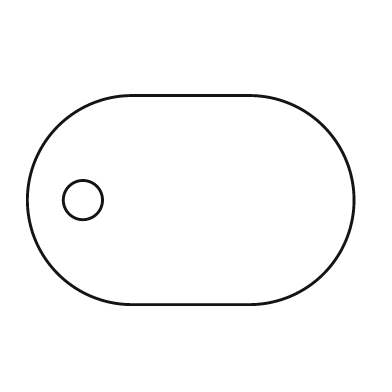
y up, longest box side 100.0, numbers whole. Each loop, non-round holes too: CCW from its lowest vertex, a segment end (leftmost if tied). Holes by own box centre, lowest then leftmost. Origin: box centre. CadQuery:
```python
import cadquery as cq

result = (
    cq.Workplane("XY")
    .moveTo(-18.0, -32.0)
    .lineTo(18.0, -32.0)
    .threePointArc((50.0, 0.0), (18.0, 32.0))
    .lineTo(-18.0, 32.0)
    .threePointArc((-50.0, 0.0), (-18.0, -32.0))
    .close()
    .moveTo(-33.0, 0.0)
    .circle(6.0)
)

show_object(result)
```